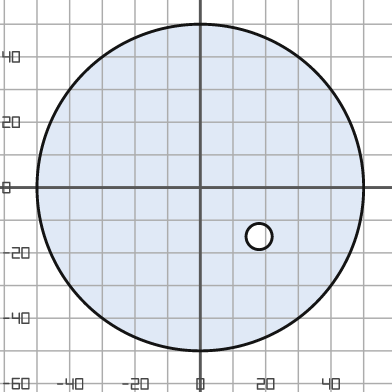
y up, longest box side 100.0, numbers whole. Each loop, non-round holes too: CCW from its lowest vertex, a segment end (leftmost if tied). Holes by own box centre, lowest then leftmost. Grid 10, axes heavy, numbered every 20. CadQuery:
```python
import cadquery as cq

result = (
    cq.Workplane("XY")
    .moveTo(0.0, 0.0)
    .circle(50.0)
    .moveTo(18.0, -15.0)
    .circle(4.0)
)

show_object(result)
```